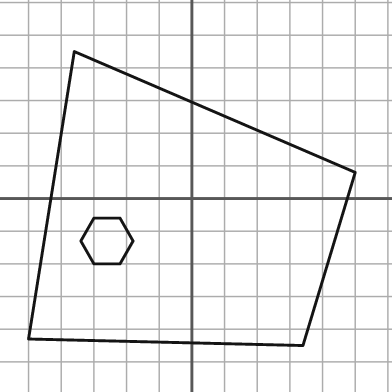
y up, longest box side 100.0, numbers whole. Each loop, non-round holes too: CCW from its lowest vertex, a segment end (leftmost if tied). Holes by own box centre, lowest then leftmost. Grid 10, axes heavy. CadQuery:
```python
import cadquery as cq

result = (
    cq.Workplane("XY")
    .moveTo(34.0, -45.0)
    .lineTo(50.0, 8.0)
    .lineTo(-36.0, 45.0)
    .lineTo(-50.0, -43.0)
    .close()
    .moveTo(-30.0, -20.0)
    .lineTo(-22.0, -20.0)
    .lineTo(-18.0, -13.0)
    .lineTo(-22.0, -6.0)
    .lineTo(-30.0, -6.0)
    .lineTo(-34.0, -13.0)
    .close()
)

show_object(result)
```